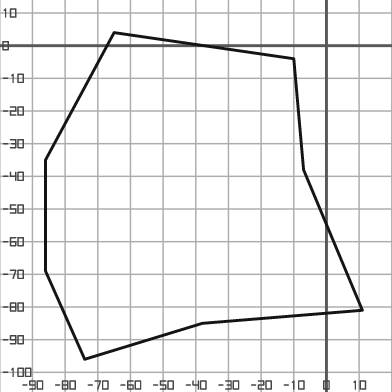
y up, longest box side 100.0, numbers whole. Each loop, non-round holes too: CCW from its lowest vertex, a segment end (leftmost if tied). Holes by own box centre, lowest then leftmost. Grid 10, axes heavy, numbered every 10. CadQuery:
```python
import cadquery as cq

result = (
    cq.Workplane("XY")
    .moveTo(-74.0, -96.0)
    .lineTo(-38.0, -85.0)
    .lineTo(11.0, -81.0)
    .lineTo(-7.0, -38.0)
    .lineTo(-10.0, -4.0)
    .lineTo(-65.0, 4.0)
    .lineTo(-86.0, -35.0)
    .lineTo(-86.0, -69.0)
    .close()
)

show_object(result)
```